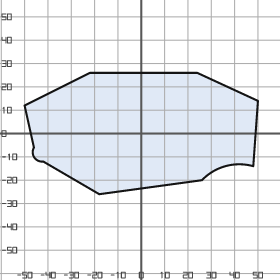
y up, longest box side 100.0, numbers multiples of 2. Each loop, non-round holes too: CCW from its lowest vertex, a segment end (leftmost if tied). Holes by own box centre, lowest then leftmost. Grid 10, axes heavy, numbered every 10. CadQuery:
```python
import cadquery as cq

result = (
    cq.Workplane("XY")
    .moveTo(-18.0, -26.0)
    .lineTo(26.0, -20.0)
    .threePointArc((36.0, -14.0), (48.0, -14.0))
    .lineTo(50.0, 14.0)
    .lineTo(24.0, 26.0)
    .lineTo(-22.0, 26.0)
    .lineTo(-50.0, 12.0)
    .lineTo(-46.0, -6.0)
    .threePointArc((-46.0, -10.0), (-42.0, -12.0))
    .close()
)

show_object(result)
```